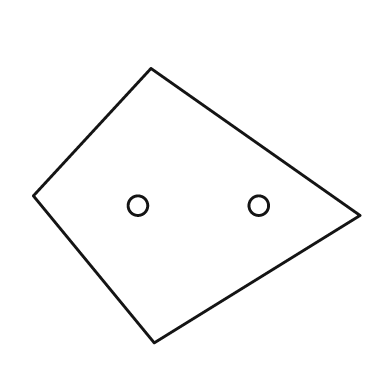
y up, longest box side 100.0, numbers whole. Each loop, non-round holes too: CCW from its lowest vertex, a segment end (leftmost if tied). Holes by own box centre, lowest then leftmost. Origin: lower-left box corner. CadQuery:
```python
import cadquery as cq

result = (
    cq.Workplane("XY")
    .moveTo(37.0, 0.0)
    .lineTo(100.0, 39.0)
    .lineTo(36.0, 84.0)
    .lineTo(0.0, 45.0)
    .close()
    .moveTo(32.0, 42.0)
    .circle(3.0)
    .moveTo(69.0, 42.0)
    .circle(3.0)
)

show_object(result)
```